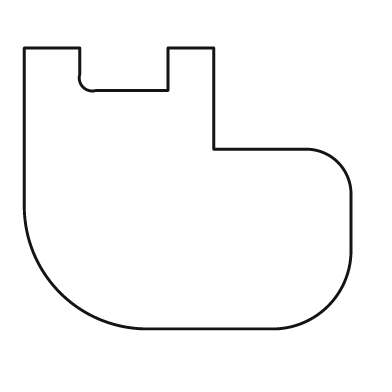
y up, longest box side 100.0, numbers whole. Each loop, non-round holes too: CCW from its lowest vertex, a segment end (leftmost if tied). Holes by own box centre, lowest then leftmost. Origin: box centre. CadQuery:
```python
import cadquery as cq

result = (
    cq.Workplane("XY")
    .moveTo(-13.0, -43.0)
    .lineTo(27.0, -43.0)
    .threePointArc((43.0, -36.0), (50.0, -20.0))
    .lineTo(50.0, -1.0)
    .threePointArc((46.0, 8.0), (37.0, 12.0))
    .lineTo(8.0, 12.0)
    .lineTo(8.0, 43.0)
    .lineTo(-6.0, 43.0)
    .lineTo(-6.0, 30.0)
    .lineTo(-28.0, 30.0)
    .threePointArc((-32.0, 31.0), (-33.0, 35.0))
    .lineTo(-33.0, 43.0)
    .lineTo(-50.0, 43.0)
    .lineTo(-50.0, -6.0)
    .threePointArc((-39.0, -32.0), (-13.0, -43.0))
    .close()
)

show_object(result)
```